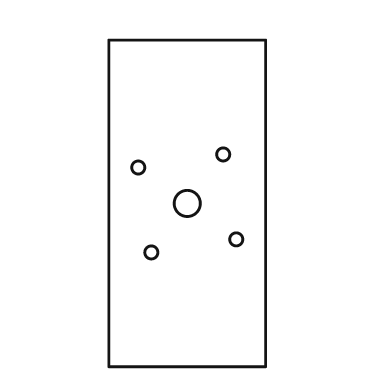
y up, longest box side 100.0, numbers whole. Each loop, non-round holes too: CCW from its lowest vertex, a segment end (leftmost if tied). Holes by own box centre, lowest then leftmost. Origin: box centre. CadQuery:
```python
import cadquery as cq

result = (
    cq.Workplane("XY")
    .moveTo(-24.0, -50.0)
    .lineTo(24.0, -50.0)
    .lineTo(24.0, 50.0)
    .lineTo(-24.0, 50.0)
    .close()
    .moveTo(-11.0, -15.0)
    .circle(2.0)
    .moveTo(15.0, -11.0)
    .circle(2.0)
    .moveTo(0.0, 0.0)
    .circle(4.0)
    .moveTo(-15.0, 11.0)
    .circle(2.0)
    .moveTo(11.0, 15.0)
    .circle(2.0)
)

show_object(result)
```